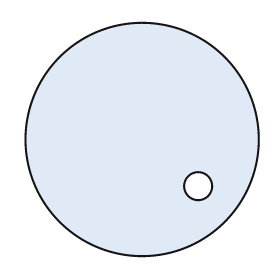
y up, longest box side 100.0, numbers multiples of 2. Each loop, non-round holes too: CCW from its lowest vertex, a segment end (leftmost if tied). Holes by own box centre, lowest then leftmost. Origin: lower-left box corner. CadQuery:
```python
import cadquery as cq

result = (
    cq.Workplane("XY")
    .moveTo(50.0, 50.0)
    .circle(50.0)
    .moveTo(74.0, 30.0)
    .circle(6.0)
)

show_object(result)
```